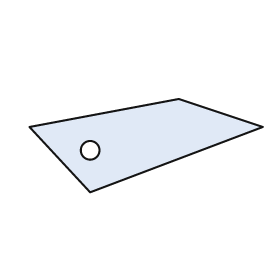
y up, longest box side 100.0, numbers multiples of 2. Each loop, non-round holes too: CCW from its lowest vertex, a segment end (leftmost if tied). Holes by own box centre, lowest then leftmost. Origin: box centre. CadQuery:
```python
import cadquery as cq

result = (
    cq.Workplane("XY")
    .moveTo(-24.0, -20.0)
    .lineTo(50.0, 8.0)
    .lineTo(14.0, 20.0)
    .lineTo(-50.0, 8.0)
    .close()
    .moveTo(-24.0, -2.0)
    .circle(4.0)
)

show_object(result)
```